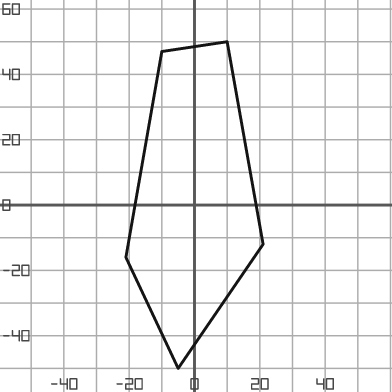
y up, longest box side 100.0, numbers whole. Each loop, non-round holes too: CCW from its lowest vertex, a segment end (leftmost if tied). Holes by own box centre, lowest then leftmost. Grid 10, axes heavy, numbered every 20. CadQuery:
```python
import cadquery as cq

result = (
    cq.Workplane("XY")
    .moveTo(-5.0, -50.0)
    .lineTo(21.0, -12.0)
    .lineTo(10.0, 50.0)
    .lineTo(-10.0, 47.0)
    .lineTo(-21.0, -16.0)
    .close()
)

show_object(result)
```